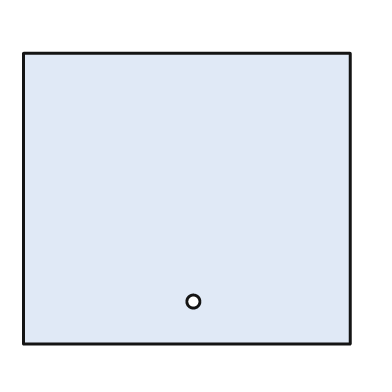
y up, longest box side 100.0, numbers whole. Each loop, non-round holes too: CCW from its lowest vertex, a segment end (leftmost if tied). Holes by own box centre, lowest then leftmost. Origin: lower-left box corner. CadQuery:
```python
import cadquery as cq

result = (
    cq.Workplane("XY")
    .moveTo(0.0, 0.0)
    .lineTo(100.0, 0.0)
    .lineTo(100.0, 89.0)
    .lineTo(0.0, 89.0)
    .close()
    .moveTo(52.0, 13.0)
    .circle(2.0)
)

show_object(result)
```